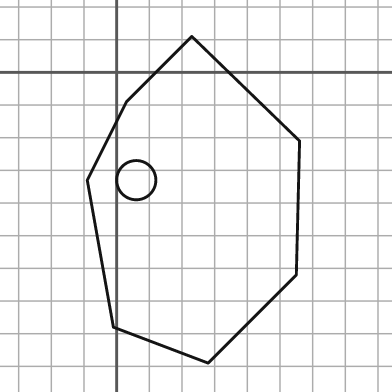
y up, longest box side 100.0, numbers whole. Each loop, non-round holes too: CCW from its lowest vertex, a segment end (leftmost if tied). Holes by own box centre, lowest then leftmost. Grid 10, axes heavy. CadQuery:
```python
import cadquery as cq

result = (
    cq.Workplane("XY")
    .moveTo(28.0, -89.0)
    .lineTo(55.0, -62.0)
    .lineTo(56.0, -21.0)
    .lineTo(23.0, 11.0)
    .lineTo(3.0, -9.0)
    .lineTo(-9.0, -33.0)
    .lineTo(-1.0, -78.0)
    .close()
    .moveTo(6.0, -33.0)
    .circle(6.0)
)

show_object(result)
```